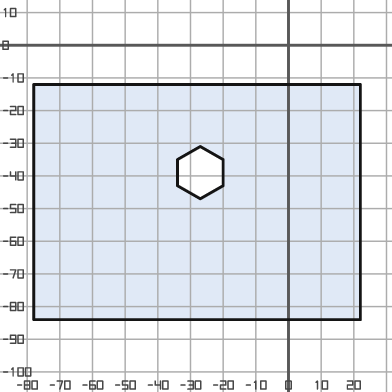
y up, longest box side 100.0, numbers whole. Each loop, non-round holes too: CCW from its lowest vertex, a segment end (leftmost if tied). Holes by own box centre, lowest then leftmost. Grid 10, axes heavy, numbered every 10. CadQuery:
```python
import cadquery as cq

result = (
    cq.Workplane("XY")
    .moveTo(-78.0, -84.0)
    .lineTo(22.0, -84.0)
    .lineTo(22.0, -12.0)
    .lineTo(-78.0, -12.0)
    .close()
    .moveTo(-27.0, -47.0)
    .lineTo(-20.0, -43.0)
    .lineTo(-20.0, -35.0)
    .lineTo(-27.0, -31.0)
    .lineTo(-34.0, -35.0)
    .lineTo(-34.0, -43.0)
    .close()
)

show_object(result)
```